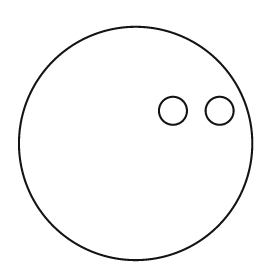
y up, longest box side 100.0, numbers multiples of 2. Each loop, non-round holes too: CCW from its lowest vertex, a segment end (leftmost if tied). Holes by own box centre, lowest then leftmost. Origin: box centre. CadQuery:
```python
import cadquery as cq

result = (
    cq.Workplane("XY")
    .moveTo(0.0, 0.0)
    .circle(50.0)
    .moveTo(16.0, 14.0)
    .circle(6.0)
    .moveTo(36.0, 14.0)
    .circle(6.0)
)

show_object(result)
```